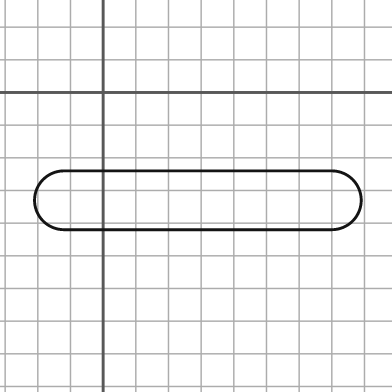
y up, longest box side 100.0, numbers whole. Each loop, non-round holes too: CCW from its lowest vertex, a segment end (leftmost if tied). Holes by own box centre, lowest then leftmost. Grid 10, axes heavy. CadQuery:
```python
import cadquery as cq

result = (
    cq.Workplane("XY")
    .moveTo(-12.0, -42.0)
    .lineTo(70.0, -42.0)
    .threePointArc((79.0, -33.0), (70.0, -24.0))
    .lineTo(-12.0, -24.0)
    .threePointArc((-21.0, -33.0), (-12.0, -42.0))
    .close()
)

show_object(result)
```